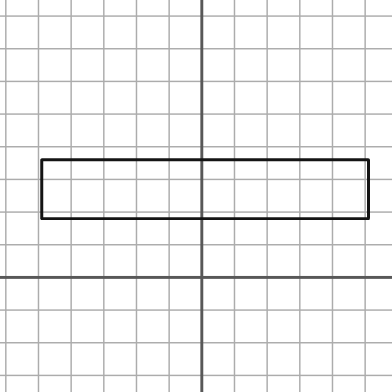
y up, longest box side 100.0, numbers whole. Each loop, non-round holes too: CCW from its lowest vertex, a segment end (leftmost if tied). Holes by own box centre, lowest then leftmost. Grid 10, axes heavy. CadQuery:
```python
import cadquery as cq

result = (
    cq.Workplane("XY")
    .moveTo(-49.0, 18.0)
    .lineTo(51.0, 18.0)
    .lineTo(51.0, 36.0)
    .lineTo(-49.0, 36.0)
    .close()
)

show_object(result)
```